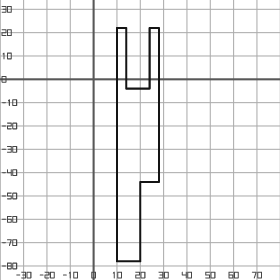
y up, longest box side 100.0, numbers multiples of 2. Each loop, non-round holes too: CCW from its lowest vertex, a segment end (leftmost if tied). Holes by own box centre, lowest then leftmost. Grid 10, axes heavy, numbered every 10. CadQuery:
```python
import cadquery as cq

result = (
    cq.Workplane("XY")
    .moveTo(10.0, -78.0)
    .lineTo(20.0, -78.0)
    .lineTo(20.0, -44.0)
    .lineTo(28.0, -44.0)
    .lineTo(28.0, 22.0)
    .lineTo(24.0, 22.0)
    .lineTo(24.0, -4.0)
    .lineTo(14.0, -4.0)
    .lineTo(14.0, 22.0)
    .lineTo(10.0, 22.0)
    .close()
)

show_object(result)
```